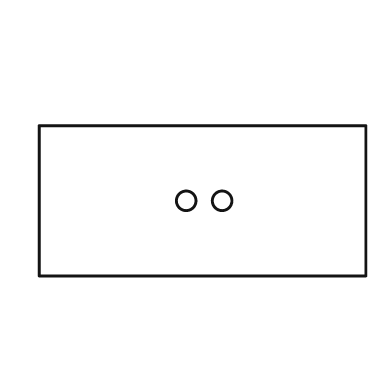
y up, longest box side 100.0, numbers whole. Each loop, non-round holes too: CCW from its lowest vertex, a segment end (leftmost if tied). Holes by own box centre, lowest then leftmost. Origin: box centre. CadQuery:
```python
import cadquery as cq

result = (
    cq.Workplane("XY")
    .moveTo(-50.0, -23.0)
    .lineTo(50.0, -23.0)
    .lineTo(50.0, 23.0)
    .lineTo(-50.0, 23.0)
    .close()
    .moveTo(-5.0, 0.0)
    .circle(3.0)
    .moveTo(6.0, 0.0)
    .circle(3.0)
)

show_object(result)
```